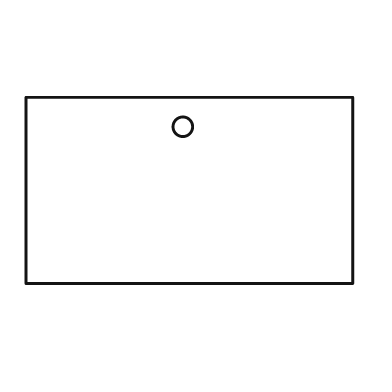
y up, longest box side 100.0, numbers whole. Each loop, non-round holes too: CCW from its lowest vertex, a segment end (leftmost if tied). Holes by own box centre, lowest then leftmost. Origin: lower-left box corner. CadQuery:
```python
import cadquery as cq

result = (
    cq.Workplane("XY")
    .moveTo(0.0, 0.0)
    .lineTo(100.0, 0.0)
    .lineTo(100.0, 57.0)
    .lineTo(0.0, 57.0)
    .close()
    .moveTo(48.0, 48.0)
    .circle(3.0)
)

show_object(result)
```